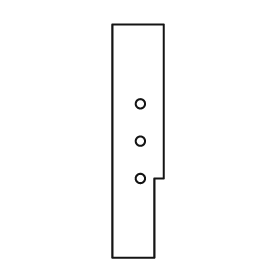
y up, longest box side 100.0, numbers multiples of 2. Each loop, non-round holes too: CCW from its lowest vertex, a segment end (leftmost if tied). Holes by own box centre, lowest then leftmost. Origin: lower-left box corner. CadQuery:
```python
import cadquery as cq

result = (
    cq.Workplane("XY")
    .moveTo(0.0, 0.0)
    .lineTo(18.0, 0.0)
    .lineTo(18.0, 34.0)
    .lineTo(22.0, 34.0)
    .lineTo(22.0, 100.0)
    .lineTo(0.0, 100.0)
    .close()
    .moveTo(12.0, 34.0)
    .circle(2.0)
    .moveTo(12.0, 50.0)
    .circle(2.0)
    .moveTo(12.0, 66.0)
    .circle(2.0)
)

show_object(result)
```